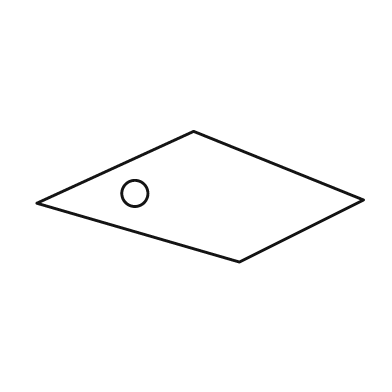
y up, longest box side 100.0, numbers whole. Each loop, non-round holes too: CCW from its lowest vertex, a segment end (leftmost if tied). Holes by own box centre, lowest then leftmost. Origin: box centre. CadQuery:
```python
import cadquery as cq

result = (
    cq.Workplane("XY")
    .moveTo(12.0, -20.0)
    .lineTo(50.0, -1.0)
    .lineTo(-2.0, 20.0)
    .lineTo(-50.0, -2.0)
    .close()
    .moveTo(-20.0, 1.0)
    .circle(4.0)
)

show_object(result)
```